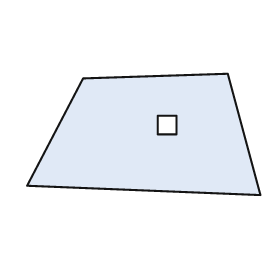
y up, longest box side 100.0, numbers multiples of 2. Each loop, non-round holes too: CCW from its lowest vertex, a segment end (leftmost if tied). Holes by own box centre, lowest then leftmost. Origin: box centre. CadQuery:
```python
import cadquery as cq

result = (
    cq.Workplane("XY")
    .moveTo(50.0, -26.0)
    .lineTo(36.0, 26.0)
    .lineTo(-26.0, 24.0)
    .lineTo(-50.0, -22.0)
    .close()
    .moveTo(6.0, 0.0)
    .lineTo(14.0, 0.0)
    .lineTo(14.0, 8.0)
    .lineTo(6.0, 8.0)
    .close()
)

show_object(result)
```